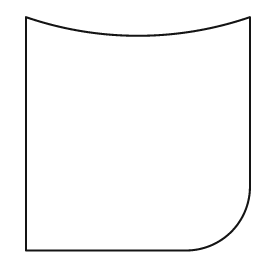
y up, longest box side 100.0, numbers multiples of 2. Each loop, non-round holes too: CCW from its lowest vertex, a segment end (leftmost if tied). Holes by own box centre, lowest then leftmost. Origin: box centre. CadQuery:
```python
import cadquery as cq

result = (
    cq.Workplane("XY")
    .moveTo(-48.0, -50.0)
    .lineTo(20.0, -50.0)
    .threePointArc((40.0, -42.0), (48.0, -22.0))
    .lineTo(48.0, 50.0)
    .threePointArc((0.0, 42.0), (-48.0, 50.0))
    .close()
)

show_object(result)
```